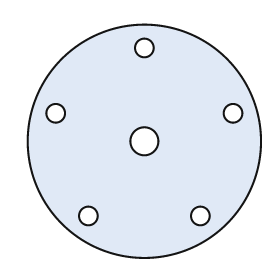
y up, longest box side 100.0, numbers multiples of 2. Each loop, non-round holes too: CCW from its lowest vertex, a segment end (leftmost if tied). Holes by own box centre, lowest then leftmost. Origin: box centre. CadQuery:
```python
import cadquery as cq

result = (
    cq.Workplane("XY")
    .moveTo(0.0, 0.0)
    .circle(50.0)
    .moveTo(-24.0, -32.0)
    .circle(4.0)
    .moveTo(24.0, -32.0)
    .circle(4.0)
    .moveTo(0.0, 0.0)
    .circle(6.0)
    .moveTo(-38.0, 12.0)
    .circle(4.0)
    .moveTo(38.0, 12.0)
    .circle(4.0)
    .moveTo(0.0, 40.0)
    .circle(4.0)
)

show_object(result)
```